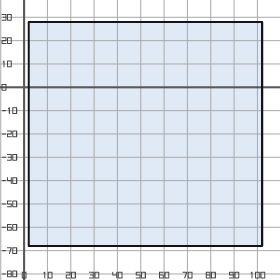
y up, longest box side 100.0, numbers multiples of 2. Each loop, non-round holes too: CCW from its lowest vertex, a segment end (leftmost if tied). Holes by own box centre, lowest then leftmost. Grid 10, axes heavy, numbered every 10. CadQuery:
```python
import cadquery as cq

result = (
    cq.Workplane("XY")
    .moveTo(2.0, -68.0)
    .lineTo(102.0, -68.0)
    .lineTo(102.0, 28.0)
    .lineTo(2.0, 28.0)
    .close()
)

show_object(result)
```